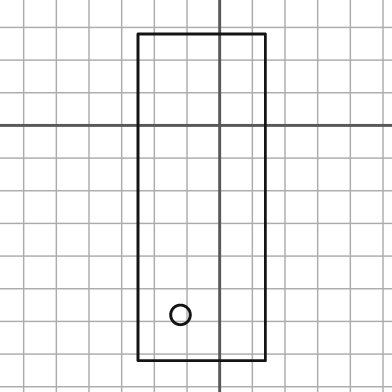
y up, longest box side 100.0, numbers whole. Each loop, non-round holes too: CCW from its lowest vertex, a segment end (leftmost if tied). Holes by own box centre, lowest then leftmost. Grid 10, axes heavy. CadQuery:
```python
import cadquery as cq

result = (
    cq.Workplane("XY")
    .moveTo(-25.0, -72.0)
    .lineTo(14.0, -72.0)
    .lineTo(14.0, 28.0)
    .lineTo(-25.0, 28.0)
    .close()
    .moveTo(-12.0, -58.0)
    .circle(3.0)
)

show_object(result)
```